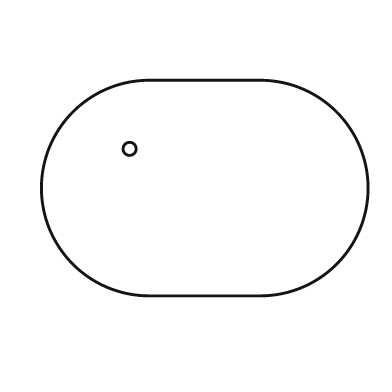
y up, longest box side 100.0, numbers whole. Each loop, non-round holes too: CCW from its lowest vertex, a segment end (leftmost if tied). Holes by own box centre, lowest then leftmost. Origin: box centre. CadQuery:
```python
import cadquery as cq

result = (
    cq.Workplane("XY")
    .moveTo(-17.0, -33.0)
    .lineTo(17.0, -33.0)
    .threePointArc((50.0, 0.0), (17.0, 33.0))
    .lineTo(-17.0, 33.0)
    .threePointArc((-50.0, 0.0), (-17.0, -33.0))
    .close()
    .moveTo(-23.0, 12.0)
    .circle(2.0)
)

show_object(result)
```